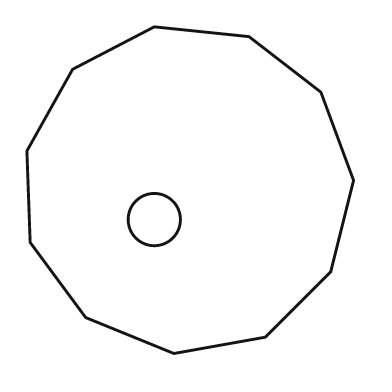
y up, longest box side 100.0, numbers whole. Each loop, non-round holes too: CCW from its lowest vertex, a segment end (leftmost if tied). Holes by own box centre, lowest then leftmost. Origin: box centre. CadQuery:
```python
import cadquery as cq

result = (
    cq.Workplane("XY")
    .moveTo(-5.0, -50.0)
    .lineTo(23.0, -45.0)
    .lineTo(43.0, -25.0)
    .lineTo(50.0, 3.0)
    .lineTo(40.0, 30.0)
    .lineTo(18.0, 47.0)
    .lineTo(-11.0, 50.0)
    .lineTo(-36.0, 37.0)
    .lineTo(-50.0, 12.0)
    .lineTo(-49.0, -16.0)
    .lineTo(-32.0, -39.0)
    .close()
    .moveTo(-11.0, -9.0)
    .circle(8.0)
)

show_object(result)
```